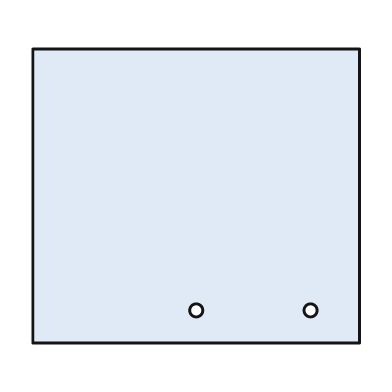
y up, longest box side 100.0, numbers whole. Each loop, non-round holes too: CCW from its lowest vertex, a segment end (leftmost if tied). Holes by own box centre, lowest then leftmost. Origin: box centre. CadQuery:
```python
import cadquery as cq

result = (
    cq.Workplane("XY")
    .moveTo(-50.0, -45.0)
    .lineTo(50.0, -45.0)
    .lineTo(50.0, 45.0)
    .lineTo(-50.0, 45.0)
    .close()
    .moveTo(0.0, -35.0)
    .circle(2.0)
    .moveTo(35.0, -35.0)
    .circle(2.0)
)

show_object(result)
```